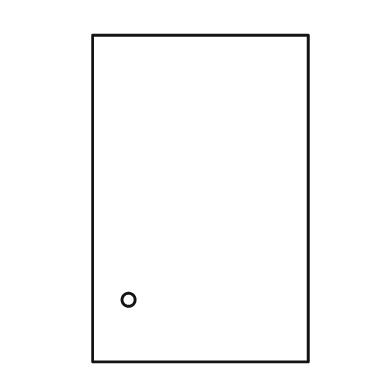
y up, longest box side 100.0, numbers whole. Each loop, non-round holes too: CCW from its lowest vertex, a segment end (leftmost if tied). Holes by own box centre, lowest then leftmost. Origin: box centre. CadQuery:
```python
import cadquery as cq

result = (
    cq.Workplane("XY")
    .moveTo(-33.0, -50.0)
    .lineTo(33.0, -50.0)
    .lineTo(33.0, 50.0)
    .lineTo(-33.0, 50.0)
    .close()
    .moveTo(-22.0, -31.0)
    .circle(2.0)
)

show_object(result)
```